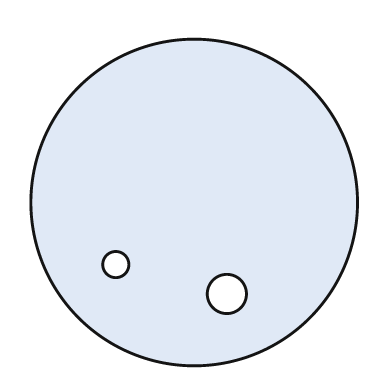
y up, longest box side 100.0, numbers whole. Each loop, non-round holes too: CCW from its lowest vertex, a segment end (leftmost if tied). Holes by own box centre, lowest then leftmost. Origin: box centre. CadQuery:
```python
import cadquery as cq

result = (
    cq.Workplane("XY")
    .moveTo(0.0, 0.0)
    .circle(50.0)
    .moveTo(10.0, -28.0)
    .circle(6.0)
    .moveTo(-24.0, -19.0)
    .circle(4.0)
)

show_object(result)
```